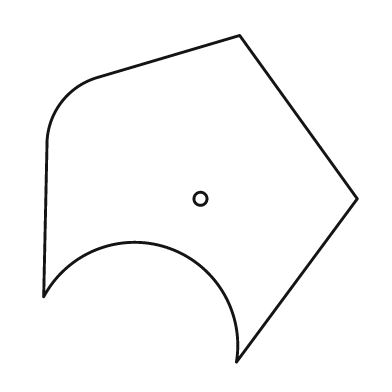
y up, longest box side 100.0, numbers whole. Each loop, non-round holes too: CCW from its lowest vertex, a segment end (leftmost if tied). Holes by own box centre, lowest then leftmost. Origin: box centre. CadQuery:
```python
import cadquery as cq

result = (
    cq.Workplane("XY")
    .moveTo(11.0, -50.0)
    .lineTo(48.0, 0.0)
    .lineTo(12.0, 50.0)
    .lineTo(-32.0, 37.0)
    .threePointArc((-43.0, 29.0), (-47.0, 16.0))
    .lineTo(-48.0, -30.0)
    .threePointArc((-10.0, -15.0), (11.0, -50.0))
    .close()
    .moveTo(0.0, 0.0)
    .circle(2.0)
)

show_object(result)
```